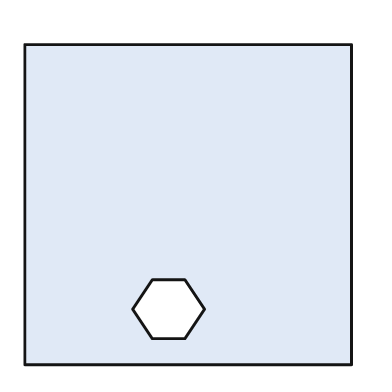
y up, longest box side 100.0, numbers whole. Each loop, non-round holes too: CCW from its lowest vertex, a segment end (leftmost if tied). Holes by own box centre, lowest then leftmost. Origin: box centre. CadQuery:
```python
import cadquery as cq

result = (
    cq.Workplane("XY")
    .moveTo(-50.0, -49.0)
    .lineTo(50.0, -49.0)
    .lineTo(50.0, 49.0)
    .lineTo(-50.0, 49.0)
    .close()
    .moveTo(-11.0, -41.0)
    .lineTo(-1.0, -41.0)
    .lineTo(5.0, -32.0)
    .lineTo(-1.0, -23.0)
    .lineTo(-11.0, -23.0)
    .lineTo(-17.0, -32.0)
    .close()
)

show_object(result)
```